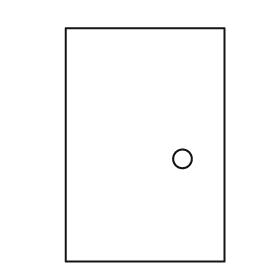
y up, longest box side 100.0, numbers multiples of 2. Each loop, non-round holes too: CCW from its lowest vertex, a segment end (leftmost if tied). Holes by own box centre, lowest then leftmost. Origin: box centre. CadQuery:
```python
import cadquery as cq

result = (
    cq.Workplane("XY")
    .moveTo(-34.0, -50.0)
    .lineTo(34.0, -50.0)
    .lineTo(34.0, 50.0)
    .lineTo(-34.0, 50.0)
    .close()
    .moveTo(16.0, -6.0)
    .circle(4.0)
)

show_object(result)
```